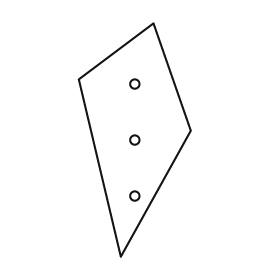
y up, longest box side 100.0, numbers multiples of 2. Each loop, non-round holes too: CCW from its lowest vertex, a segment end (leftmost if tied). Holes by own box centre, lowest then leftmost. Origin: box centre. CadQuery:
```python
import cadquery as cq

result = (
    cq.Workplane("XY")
    .moveTo(-6.0, -50.0)
    .lineTo(24.0, 4.0)
    .lineTo(8.0, 50.0)
    .lineTo(-24.0, 26.0)
    .close()
    .moveTo(0.0, -24.0)
    .circle(2.0)
    .moveTo(0.0, 0.0)
    .circle(2.0)
    .moveTo(0.0, 24.0)
    .circle(2.0)
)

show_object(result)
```